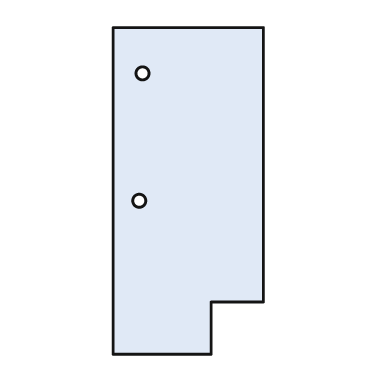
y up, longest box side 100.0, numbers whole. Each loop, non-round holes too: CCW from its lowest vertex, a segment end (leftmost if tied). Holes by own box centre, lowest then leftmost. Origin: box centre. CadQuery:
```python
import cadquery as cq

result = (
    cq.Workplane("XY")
    .moveTo(-23.0, -50.0)
    .lineTo(7.0, -50.0)
    .lineTo(7.0, -34.0)
    .lineTo(23.0, -34.0)
    .lineTo(23.0, 50.0)
    .lineTo(-23.0, 50.0)
    .close()
    .moveTo(-15.0, -3.0)
    .circle(2.0)
    .moveTo(-14.0, 36.0)
    .circle(2.0)
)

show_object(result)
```